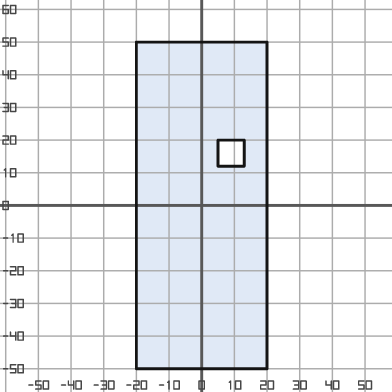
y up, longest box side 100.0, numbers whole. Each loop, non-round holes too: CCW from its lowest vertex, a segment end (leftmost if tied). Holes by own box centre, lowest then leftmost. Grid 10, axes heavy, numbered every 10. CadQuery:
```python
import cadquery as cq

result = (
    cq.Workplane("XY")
    .moveTo(-20.0, -50.0)
    .lineTo(20.0, -50.0)
    .lineTo(20.0, 50.0)
    .lineTo(-20.0, 50.0)
    .close()
    .moveTo(5.0, 12.0)
    .lineTo(13.0, 12.0)
    .lineTo(13.0, 20.0)
    .lineTo(5.0, 20.0)
    .close()
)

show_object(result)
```